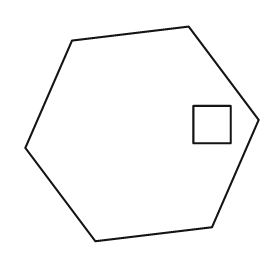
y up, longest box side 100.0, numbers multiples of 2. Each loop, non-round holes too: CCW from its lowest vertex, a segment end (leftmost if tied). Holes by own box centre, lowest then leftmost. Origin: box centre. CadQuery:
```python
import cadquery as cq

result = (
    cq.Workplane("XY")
    .moveTo(-20.0, -46.0)
    .lineTo(30.0, -40.0)
    .lineTo(50.0, 6.0)
    .lineTo(20.0, 46.0)
    .lineTo(-30.0, 40.0)
    .lineTo(-50.0, -6.0)
    .close()
    .moveTo(22.0, -4.0)
    .lineTo(38.0, -4.0)
    .lineTo(38.0, 12.0)
    .lineTo(22.0, 12.0)
    .close()
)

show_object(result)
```